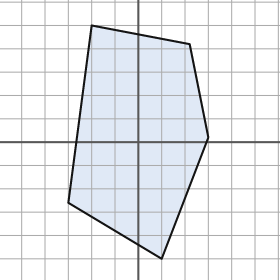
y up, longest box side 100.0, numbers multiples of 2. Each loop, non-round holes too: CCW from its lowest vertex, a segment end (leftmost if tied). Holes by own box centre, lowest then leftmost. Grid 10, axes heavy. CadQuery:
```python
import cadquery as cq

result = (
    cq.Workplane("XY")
    .moveTo(10.0, -50.0)
    .lineTo(30.0, 2.0)
    .lineTo(22.0, 42.0)
    .lineTo(-20.0, 50.0)
    .lineTo(-30.0, -26.0)
    .close()
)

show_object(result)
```